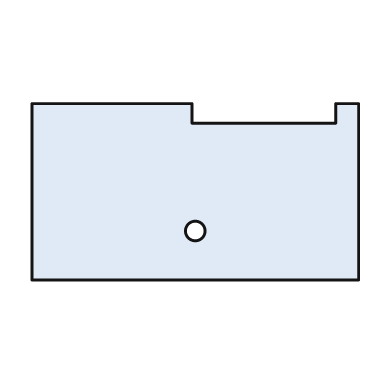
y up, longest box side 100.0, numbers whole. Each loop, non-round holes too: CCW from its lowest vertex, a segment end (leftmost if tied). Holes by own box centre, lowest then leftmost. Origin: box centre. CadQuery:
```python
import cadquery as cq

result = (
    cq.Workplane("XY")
    .moveTo(-50.0, -27.0)
    .lineTo(50.0, -27.0)
    .lineTo(50.0, 27.0)
    .lineTo(43.0, 27.0)
    .lineTo(43.0, 21.0)
    .lineTo(-1.0, 21.0)
    .lineTo(-1.0, 27.0)
    .lineTo(-50.0, 27.0)
    .close()
    .moveTo(0.0, -12.0)
    .circle(3.0)
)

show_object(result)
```